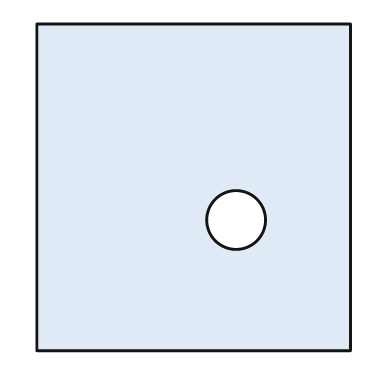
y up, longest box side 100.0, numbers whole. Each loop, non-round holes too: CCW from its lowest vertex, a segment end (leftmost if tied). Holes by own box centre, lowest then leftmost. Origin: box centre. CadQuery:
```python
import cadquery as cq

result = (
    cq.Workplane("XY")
    .moveTo(-48.0, -50.0)
    .lineTo(48.0, -50.0)
    .lineTo(48.0, 50.0)
    .lineTo(-48.0, 50.0)
    .close()
    .moveTo(13.0, -10.0)
    .circle(9.0)
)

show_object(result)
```